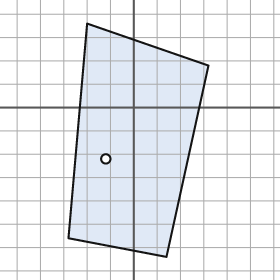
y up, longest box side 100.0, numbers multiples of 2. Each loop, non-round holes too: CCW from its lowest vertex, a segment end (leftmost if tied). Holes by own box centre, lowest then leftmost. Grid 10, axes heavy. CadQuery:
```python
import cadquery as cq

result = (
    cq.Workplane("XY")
    .moveTo(14.0, -64.0)
    .lineTo(32.0, 18.0)
    .lineTo(-20.0, 36.0)
    .lineTo(-28.0, -56.0)
    .close()
    .moveTo(-12.0, -22.0)
    .circle(2.0)
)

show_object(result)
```